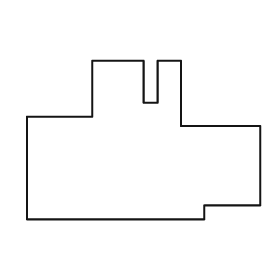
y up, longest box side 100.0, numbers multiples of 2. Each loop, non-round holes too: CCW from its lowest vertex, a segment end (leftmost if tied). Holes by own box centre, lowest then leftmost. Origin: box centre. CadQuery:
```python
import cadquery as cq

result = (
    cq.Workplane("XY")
    .moveTo(-50.0, -34.0)
    .lineTo(26.0, -34.0)
    .lineTo(26.0, -28.0)
    .lineTo(50.0, -28.0)
    .lineTo(50.0, 6.0)
    .lineTo(16.0, 6.0)
    .lineTo(16.0, 34.0)
    .lineTo(6.0, 34.0)
    .lineTo(6.0, 16.0)
    .lineTo(0.0, 16.0)
    .lineTo(0.0, 34.0)
    .lineTo(-22.0, 34.0)
    .lineTo(-22.0, 10.0)
    .lineTo(-50.0, 10.0)
    .close()
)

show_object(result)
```